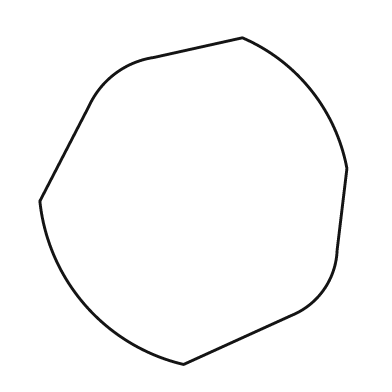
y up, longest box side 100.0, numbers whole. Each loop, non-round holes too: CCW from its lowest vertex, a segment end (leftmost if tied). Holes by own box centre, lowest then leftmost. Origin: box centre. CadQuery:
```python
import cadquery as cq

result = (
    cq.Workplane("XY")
    .moveTo(-3.0, -50.0)
    .lineTo(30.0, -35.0)
    .threePointArc((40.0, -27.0), (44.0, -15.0))
    .lineTo(47.0, 10.0)
    .threePointArc((36.0, 34.0), (15.0, 50.0))
    .lineTo(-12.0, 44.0)
    .threePointArc((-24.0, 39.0), (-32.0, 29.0))
    .lineTo(-47.0, 0.0)
    .threePointArc((-33.0, -32.0), (-3.0, -50.0))
    .close()
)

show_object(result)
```